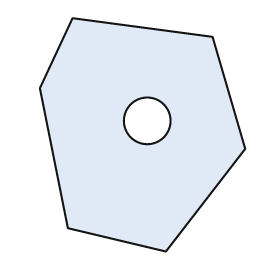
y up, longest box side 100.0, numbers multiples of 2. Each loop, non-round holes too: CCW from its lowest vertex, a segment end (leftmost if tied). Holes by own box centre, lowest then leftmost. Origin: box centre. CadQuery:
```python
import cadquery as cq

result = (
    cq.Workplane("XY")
    .moveTo(10.0, -50.0)
    .lineTo(44.0, -6.0)
    .lineTo(30.0, 42.0)
    .lineTo(-30.0, 50.0)
    .lineTo(-44.0, 20.0)
    .lineTo(-32.0, -40.0)
    .close()
    .moveTo(2.0, 6.0)
    .circle(10.0)
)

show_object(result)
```